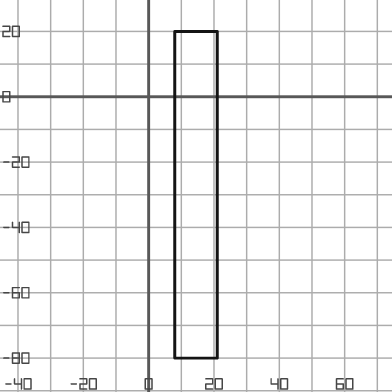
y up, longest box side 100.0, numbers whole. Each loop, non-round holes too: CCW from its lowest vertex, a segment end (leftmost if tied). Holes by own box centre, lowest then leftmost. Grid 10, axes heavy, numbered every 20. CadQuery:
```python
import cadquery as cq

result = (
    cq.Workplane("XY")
    .moveTo(8.0, -80.0)
    .lineTo(21.0, -80.0)
    .lineTo(21.0, 20.0)
    .lineTo(8.0, 20.0)
    .close()
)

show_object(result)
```